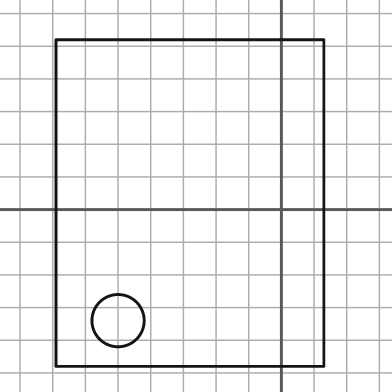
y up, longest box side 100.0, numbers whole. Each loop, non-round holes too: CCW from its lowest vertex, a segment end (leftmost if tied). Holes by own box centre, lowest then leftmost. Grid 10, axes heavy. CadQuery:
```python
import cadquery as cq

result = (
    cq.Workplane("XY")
    .moveTo(-69.0, -48.0)
    .lineTo(13.0, -48.0)
    .lineTo(13.0, 52.0)
    .lineTo(-69.0, 52.0)
    .close()
    .moveTo(-50.0, -34.0)
    .circle(8.0)
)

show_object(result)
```